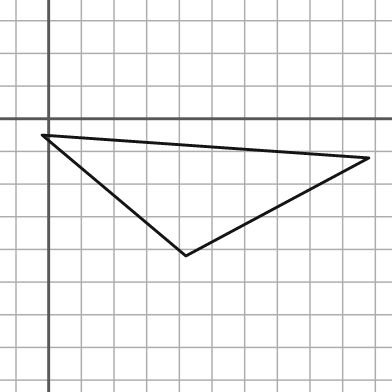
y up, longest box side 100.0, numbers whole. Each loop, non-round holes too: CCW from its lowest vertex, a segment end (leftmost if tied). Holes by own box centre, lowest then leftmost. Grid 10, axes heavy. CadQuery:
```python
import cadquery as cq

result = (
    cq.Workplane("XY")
    .moveTo(42.0, -42.0)
    .lineTo(98.0, -12.0)
    .lineTo(-2.0, -5.0)
    .close()
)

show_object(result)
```